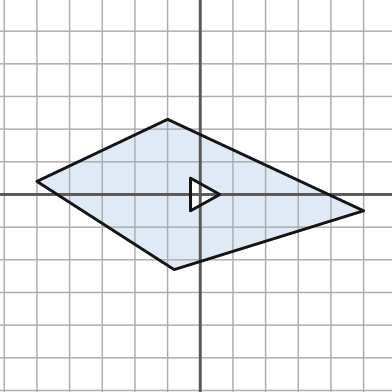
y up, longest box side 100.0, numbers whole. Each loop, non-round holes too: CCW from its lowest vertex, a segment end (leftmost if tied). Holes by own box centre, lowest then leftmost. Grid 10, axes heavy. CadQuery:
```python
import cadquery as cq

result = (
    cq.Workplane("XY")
    .moveTo(-8.0, -23.0)
    .lineTo(50.0, -5.0)
    .lineTo(-10.0, 23.0)
    .lineTo(-50.0, 4.0)
    .close()
    .moveTo(-3.0, -5.0)
    .lineTo(6.0, 0.0)
    .lineTo(-3.0, 5.0)
    .close()
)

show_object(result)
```